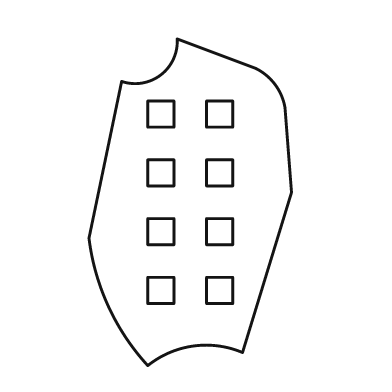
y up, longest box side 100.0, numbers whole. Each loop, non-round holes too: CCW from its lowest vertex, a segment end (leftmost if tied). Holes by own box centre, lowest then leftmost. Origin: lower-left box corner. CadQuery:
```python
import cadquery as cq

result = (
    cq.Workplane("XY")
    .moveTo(18.0, 0.0)
    .threePointArc((32.0, 6.0), (47.0, 4.0))
    .lineTo(62.0, 53.0)
    .lineTo(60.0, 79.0)
    .threePointArc((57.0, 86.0), (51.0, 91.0))
    .lineTo(27.0, 100.0)
    .threePointArc((22.0, 89.0), (10.0, 87.0))
    .lineTo(0.0, 39.0)
    .threePointArc((6.0, 18.0), (18.0, 0.0))
    .close()
    .moveTo(18.0, 19.0)
    .lineTo(26.0, 19.0)
    .lineTo(26.0, 27.0)
    .lineTo(18.0, 27.0)
    .close()
    .moveTo(36.0, 19.0)
    .lineTo(44.0, 19.0)
    .lineTo(44.0, 27.0)
    .lineTo(36.0, 27.0)
    .close()
    .moveTo(18.0, 37.0)
    .lineTo(26.0, 37.0)
    .lineTo(26.0, 45.0)
    .lineTo(18.0, 45.0)
    .close()
    .moveTo(36.0, 37.0)
    .lineTo(44.0, 37.0)
    .lineTo(44.0, 45.0)
    .lineTo(36.0, 45.0)
    .close()
    .moveTo(18.0, 55.0)
    .lineTo(26.0, 55.0)
    .lineTo(26.0, 63.0)
    .lineTo(18.0, 63.0)
    .close()
    .moveTo(36.0, 55.0)
    .lineTo(44.0, 55.0)
    .lineTo(44.0, 63.0)
    .lineTo(36.0, 63.0)
    .close()
    .moveTo(18.0, 73.0)
    .lineTo(26.0, 73.0)
    .lineTo(26.0, 81.0)
    .lineTo(18.0, 81.0)
    .close()
    .moveTo(36.0, 73.0)
    .lineTo(44.0, 73.0)
    .lineTo(44.0, 81.0)
    .lineTo(36.0, 81.0)
    .close()
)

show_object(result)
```